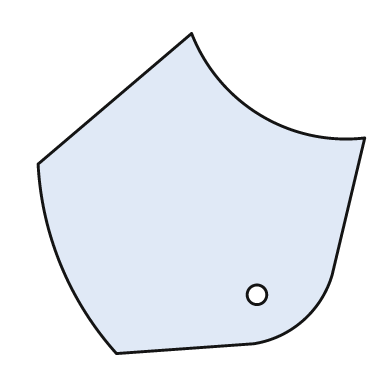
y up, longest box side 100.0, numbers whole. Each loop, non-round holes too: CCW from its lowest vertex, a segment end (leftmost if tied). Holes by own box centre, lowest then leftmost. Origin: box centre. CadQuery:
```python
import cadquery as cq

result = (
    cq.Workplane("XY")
    .moveTo(-26.0, -49.0)
    .lineTo(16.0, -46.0)
    .threePointArc((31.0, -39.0), (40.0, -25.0))
    .lineTo(50.0, 17.0)
    .threePointArc((18.0, 24.0), (-3.0, 49.0))
    .lineTo(-50.0, 9.0)
    .threePointArc((-43.0, -22.0), (-26.0, -49.0))
    .close()
    .moveTo(17.0, -31.0)
    .circle(3.0)
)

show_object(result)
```